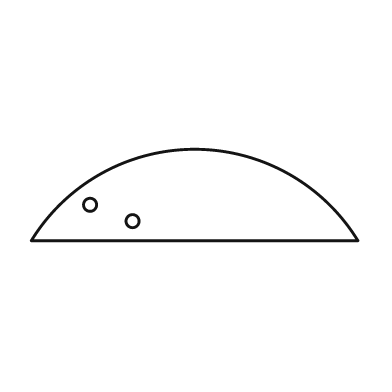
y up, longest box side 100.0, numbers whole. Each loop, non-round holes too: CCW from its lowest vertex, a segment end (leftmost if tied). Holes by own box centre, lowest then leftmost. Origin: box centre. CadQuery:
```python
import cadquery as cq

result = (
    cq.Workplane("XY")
    .moveTo(-50.0, -14.0)
    .lineTo(50.0, -14.0)
    .threePointArc((0.0, 14.0), (-50.0, -14.0))
    .close()
    .moveTo(-19.0, -8.0)
    .circle(2.0)
    .moveTo(-32.0, -3.0)
    .circle(2.0)
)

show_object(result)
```